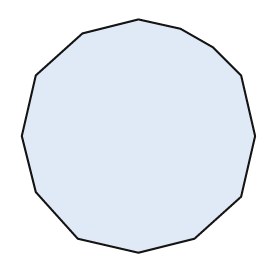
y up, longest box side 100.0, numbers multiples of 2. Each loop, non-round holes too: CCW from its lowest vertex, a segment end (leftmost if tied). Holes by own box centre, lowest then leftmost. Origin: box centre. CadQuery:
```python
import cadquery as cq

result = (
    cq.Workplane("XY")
    .moveTo(0.0, -50.0)
    .lineTo(24.0, -44.0)
    .lineTo(44.0, -26.0)
    .lineTo(50.0, 0.0)
    .lineTo(44.0, 26.0)
    .lineTo(32.0, 38.0)
    .lineTo(18.0, 46.0)
    .lineTo(0.0, 50.0)
    .lineTo(-24.0, 44.0)
    .lineTo(-44.0, 26.0)
    .lineTo(-50.0, 0.0)
    .lineTo(-44.0, -24.0)
    .lineTo(-26.0, -44.0)
    .close()
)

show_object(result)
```